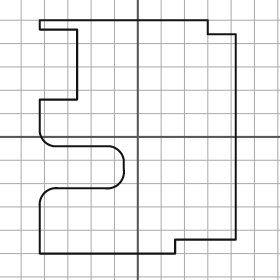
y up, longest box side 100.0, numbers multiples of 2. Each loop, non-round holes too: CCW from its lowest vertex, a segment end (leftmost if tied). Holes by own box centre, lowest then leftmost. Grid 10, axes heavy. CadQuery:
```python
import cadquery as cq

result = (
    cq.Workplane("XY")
    .moveTo(-42.0, -50.0)
    .lineTo(16.0, -50.0)
    .lineTo(16.0, -44.0)
    .lineTo(42.0, -44.0)
    .lineTo(42.0, 44.0)
    .lineTo(30.0, 44.0)
    .lineTo(30.0, 50.0)
    .lineTo(-42.0, 50.0)
    .lineTo(-42.0, 46.0)
    .lineTo(-26.0, 46.0)
    .lineTo(-26.0, 16.0)
    .lineTo(-42.0, 16.0)
    .lineTo(-42.0, 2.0)
    .threePointArc((-40.0, -2.0), (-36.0, -4.0))
    .lineTo(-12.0, -4.0)
    .threePointArc((-8.0, -6.0), (-6.0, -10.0))
    .lineTo(-6.0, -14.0)
    .threePointArc((-8.0, -20.0), (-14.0, -22.0))
    .lineTo(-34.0, -22.0)
    .threePointArc((-40.0, -24.0), (-42.0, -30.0))
    .close()
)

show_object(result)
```